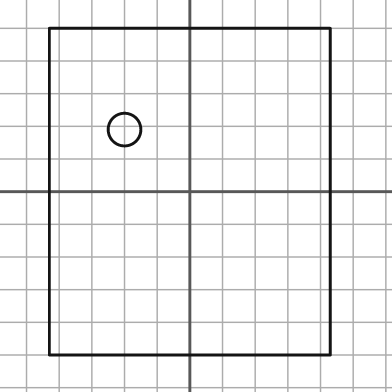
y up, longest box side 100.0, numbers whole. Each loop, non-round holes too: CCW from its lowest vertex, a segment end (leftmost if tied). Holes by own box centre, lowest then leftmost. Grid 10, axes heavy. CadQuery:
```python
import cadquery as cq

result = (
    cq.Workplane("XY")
    .moveTo(-43.0, -50.0)
    .lineTo(43.0, -50.0)
    .lineTo(43.0, 50.0)
    .lineTo(-43.0, 50.0)
    .close()
    .moveTo(-20.0, 19.0)
    .circle(5.0)
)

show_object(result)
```